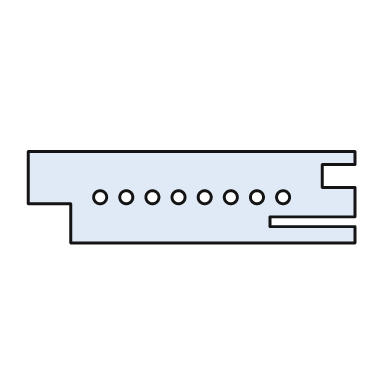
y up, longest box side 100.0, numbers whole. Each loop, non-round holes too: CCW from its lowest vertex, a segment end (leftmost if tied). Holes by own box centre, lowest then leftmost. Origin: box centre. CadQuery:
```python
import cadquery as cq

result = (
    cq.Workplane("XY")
    .moveTo(-37.0, -14.0)
    .lineTo(50.0, -14.0)
    .lineTo(50.0, -9.0)
    .lineTo(24.0, -9.0)
    .lineTo(24.0, -6.0)
    .lineTo(50.0, -6.0)
    .lineTo(50.0, 3.0)
    .lineTo(40.0, 3.0)
    .lineTo(40.0, 10.0)
    .lineTo(50.0, 10.0)
    .lineTo(50.0, 14.0)
    .lineTo(-50.0, 14.0)
    .lineTo(-50.0, -2.0)
    .lineTo(-37.0, -2.0)
    .close()
    .moveTo(-28.0, 0.0)
    .circle(2.0)
    .moveTo(-20.0, 0.0)
    .circle(2.0)
    .moveTo(-12.0, 0.0)
    .circle(2.0)
    .moveTo(-4.0, 0.0)
    .circle(2.0)
    .moveTo(4.0, 0.0)
    .circle(2.0)
    .moveTo(12.0, 0.0)
    .circle(2.0)
    .moveTo(20.0, 0.0)
    .circle(2.0)
    .moveTo(28.0, 0.0)
    .circle(2.0)
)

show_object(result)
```